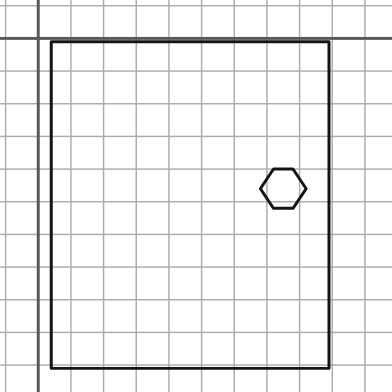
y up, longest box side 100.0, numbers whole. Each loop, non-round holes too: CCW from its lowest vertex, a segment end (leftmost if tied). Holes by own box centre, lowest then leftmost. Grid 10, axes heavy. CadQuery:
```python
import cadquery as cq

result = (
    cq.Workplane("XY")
    .moveTo(4.0, -101.0)
    .lineTo(89.0, -101.0)
    .lineTo(89.0, -1.0)
    .lineTo(4.0, -1.0)
    .close()
    .moveTo(72.0, -52.0)
    .lineTo(78.0, -52.0)
    .lineTo(82.0, -46.0)
    .lineTo(78.0, -40.0)
    .lineTo(72.0, -40.0)
    .lineTo(68.0, -46.0)
    .close()
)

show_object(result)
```